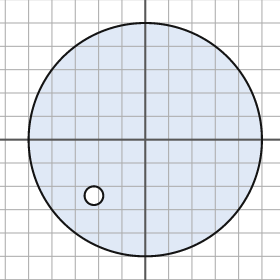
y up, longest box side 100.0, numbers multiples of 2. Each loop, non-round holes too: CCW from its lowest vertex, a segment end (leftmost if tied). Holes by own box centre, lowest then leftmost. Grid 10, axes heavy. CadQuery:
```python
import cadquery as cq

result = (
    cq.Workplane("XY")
    .moveTo(0.0, 0.0)
    .circle(50.0)
    .moveTo(-22.0, -24.0)
    .circle(4.0)
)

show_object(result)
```